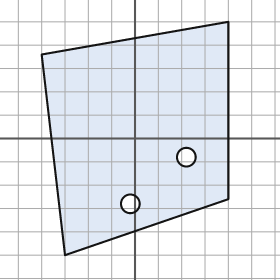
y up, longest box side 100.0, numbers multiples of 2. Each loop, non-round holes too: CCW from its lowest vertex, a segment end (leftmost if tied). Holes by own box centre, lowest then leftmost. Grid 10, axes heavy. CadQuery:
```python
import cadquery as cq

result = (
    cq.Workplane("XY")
    .moveTo(-30.0, -50.0)
    .lineTo(40.0, -26.0)
    .lineTo(40.0, 50.0)
    .lineTo(-40.0, 36.0)
    .close()
    .moveTo(-2.0, -28.0)
    .circle(4.0)
    .moveTo(22.0, -8.0)
    .circle(4.0)
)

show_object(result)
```